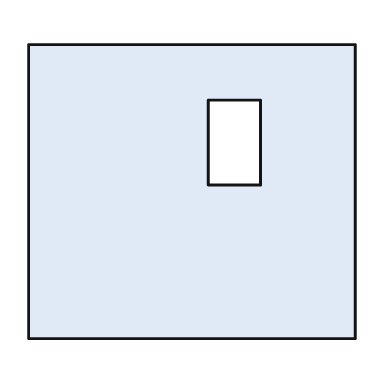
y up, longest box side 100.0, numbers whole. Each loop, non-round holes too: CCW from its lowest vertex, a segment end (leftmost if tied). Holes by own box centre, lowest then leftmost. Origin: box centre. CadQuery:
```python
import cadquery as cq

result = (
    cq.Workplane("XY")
    .moveTo(-50.0, -45.0)
    .lineTo(50.0, -45.0)
    .lineTo(50.0, 45.0)
    .lineTo(-50.0, 45.0)
    .close()
    .moveTo(5.0, 2.0)
    .lineTo(21.0, 2.0)
    .lineTo(21.0, 28.0)
    .lineTo(5.0, 28.0)
    .close()
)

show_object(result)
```